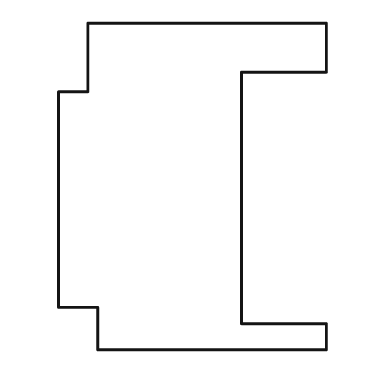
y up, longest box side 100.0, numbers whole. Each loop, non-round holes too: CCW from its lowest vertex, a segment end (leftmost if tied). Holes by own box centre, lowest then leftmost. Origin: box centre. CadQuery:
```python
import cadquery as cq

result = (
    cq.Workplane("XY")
    .moveTo(-29.0, -50.0)
    .lineTo(41.0, -50.0)
    .lineTo(41.0, -42.0)
    .lineTo(15.0, -42.0)
    .lineTo(15.0, 35.0)
    .lineTo(41.0, 35.0)
    .lineTo(41.0, 50.0)
    .lineTo(-32.0, 50.0)
    .lineTo(-32.0, 29.0)
    .lineTo(-41.0, 29.0)
    .lineTo(-41.0, -37.0)
    .lineTo(-29.0, -37.0)
    .close()
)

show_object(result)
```